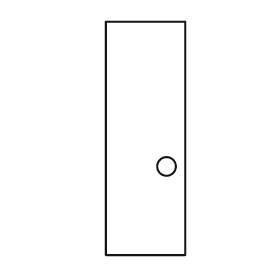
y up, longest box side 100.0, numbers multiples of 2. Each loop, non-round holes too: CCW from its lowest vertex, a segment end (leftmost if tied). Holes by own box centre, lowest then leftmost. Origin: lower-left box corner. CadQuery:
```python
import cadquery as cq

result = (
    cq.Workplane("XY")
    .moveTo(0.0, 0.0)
    .lineTo(34.0, 0.0)
    .lineTo(34.0, 100.0)
    .lineTo(0.0, 100.0)
    .close()
    .moveTo(26.0, 38.0)
    .circle(4.0)
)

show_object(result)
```